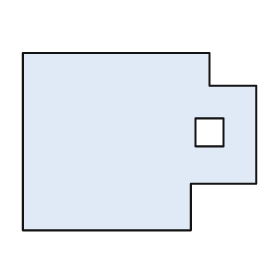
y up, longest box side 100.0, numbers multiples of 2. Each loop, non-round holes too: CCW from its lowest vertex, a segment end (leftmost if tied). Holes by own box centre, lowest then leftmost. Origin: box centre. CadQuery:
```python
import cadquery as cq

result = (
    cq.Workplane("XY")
    .moveTo(-50.0, -38.0)
    .lineTo(22.0, -38.0)
    .lineTo(22.0, -18.0)
    .lineTo(50.0, -18.0)
    .lineTo(50.0, 24.0)
    .lineTo(30.0, 24.0)
    .lineTo(30.0, 38.0)
    .lineTo(-50.0, 38.0)
    .close()
    .moveTo(24.0, -2.0)
    .lineTo(36.0, -2.0)
    .lineTo(36.0, 10.0)
    .lineTo(24.0, 10.0)
    .close()
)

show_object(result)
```